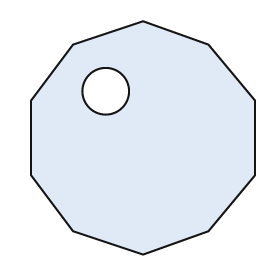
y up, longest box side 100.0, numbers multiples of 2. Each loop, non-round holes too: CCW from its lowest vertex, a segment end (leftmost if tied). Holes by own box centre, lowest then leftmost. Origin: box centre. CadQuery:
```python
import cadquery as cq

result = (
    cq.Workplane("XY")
    .moveTo(0.0, -50.0)
    .lineTo(28.0, -40.0)
    .lineTo(48.0, -16.0)
    .lineTo(48.0, 16.0)
    .lineTo(28.0, 40.0)
    .lineTo(0.0, 50.0)
    .lineTo(-30.0, 40.0)
    .lineTo(-48.0, 16.0)
    .lineTo(-48.0, -16.0)
    .lineTo(-30.0, -40.0)
    .close()
    .moveTo(-16.0, 20.0)
    .circle(10.0)
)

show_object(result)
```